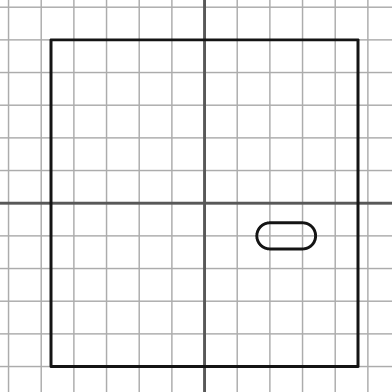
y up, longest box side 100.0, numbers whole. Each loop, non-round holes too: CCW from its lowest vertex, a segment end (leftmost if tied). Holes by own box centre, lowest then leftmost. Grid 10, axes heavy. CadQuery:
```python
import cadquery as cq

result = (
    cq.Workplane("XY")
    .moveTo(-47.0, -50.0)
    .lineTo(47.0, -50.0)
    .lineTo(47.0, 50.0)
    .lineTo(-47.0, 50.0)
    .close()
    .moveTo(20.0, -14.0)
    .lineTo(30.0, -14.0)
    .threePointArc((34.0, -10.0), (30.0, -6.0))
    .lineTo(20.0, -6.0)
    .threePointArc((16.0, -10.0), (20.0, -14.0))
    .close()
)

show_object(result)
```